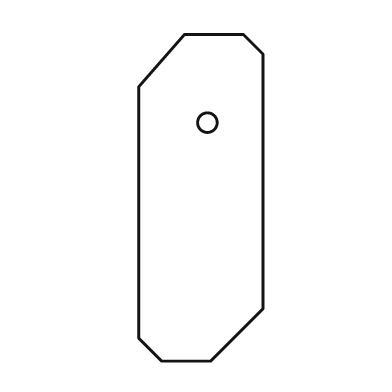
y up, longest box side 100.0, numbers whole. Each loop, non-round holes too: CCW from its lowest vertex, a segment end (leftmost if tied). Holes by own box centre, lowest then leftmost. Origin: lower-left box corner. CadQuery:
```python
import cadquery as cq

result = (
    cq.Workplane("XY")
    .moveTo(7.0, 0.0)
    .lineTo(22.0, 0.0)
    .lineTo(38.0, 16.0)
    .lineTo(38.0, 94.0)
    .lineTo(32.0, 100.0)
    .lineTo(14.0, 100.0)
    .lineTo(0.0, 84.0)
    .lineTo(0.0, 7.0)
    .close()
    .moveTo(21.0, 73.0)
    .circle(3.0)
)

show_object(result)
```